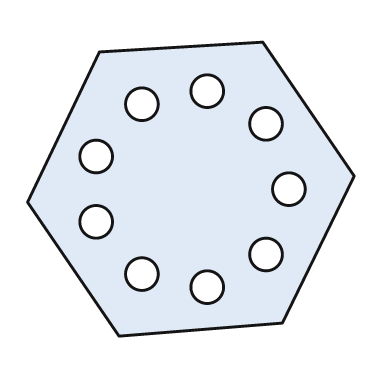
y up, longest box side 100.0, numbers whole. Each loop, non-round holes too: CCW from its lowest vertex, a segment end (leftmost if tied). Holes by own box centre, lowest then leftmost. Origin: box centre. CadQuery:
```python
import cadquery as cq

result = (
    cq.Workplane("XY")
    .moveTo(-22.0, -45.0)
    .lineTo(28.0, -41.0)
    .lineTo(50.0, 4.0)
    .lineTo(22.0, 45.0)
    .lineTo(-28.0, 42.0)
    .lineTo(-50.0, -4.0)
    .close()
    .moveTo(5.0, -30.0)
    .circle(5.0)
    .moveTo(-15.0, -26.0)
    .circle(5.0)
    .moveTo(23.0, -20.0)
    .circle(5.0)
    .moveTo(-29.0, -10.0)
    .circle(5.0)
    .moveTo(30.0, 0.0)
    .circle(5.0)
    .moveTo(-29.0, 10.0)
    .circle(5.0)
    .moveTo(23.0, 20.0)
    .circle(5.0)
    .moveTo(-15.0, 26.0)
    .circle(5.0)
    .moveTo(5.0, 30.0)
    .circle(5.0)
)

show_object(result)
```